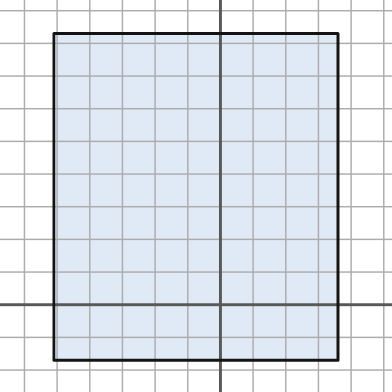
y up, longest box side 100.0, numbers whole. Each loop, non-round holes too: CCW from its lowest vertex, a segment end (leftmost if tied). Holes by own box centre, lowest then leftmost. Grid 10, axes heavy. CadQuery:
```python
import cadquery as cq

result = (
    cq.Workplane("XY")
    .moveTo(-51.0, -17.0)
    .lineTo(36.0, -17.0)
    .lineTo(36.0, 83.0)
    .lineTo(-51.0, 83.0)
    .close()
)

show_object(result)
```